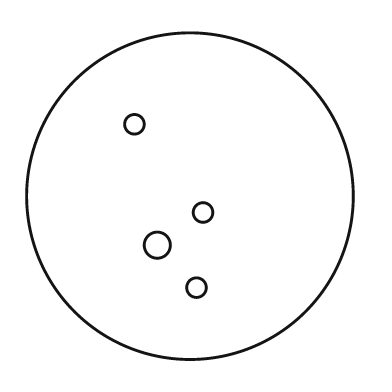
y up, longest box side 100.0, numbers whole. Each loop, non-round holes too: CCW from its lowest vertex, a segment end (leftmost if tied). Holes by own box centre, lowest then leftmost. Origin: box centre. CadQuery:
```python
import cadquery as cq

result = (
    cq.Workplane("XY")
    .moveTo(0.0, 0.0)
    .circle(50.0)
    .moveTo(2.0, -28.0)
    .circle(3.0)
    .moveTo(-10.0, -15.0)
    .circle(4.0)
    .moveTo(4.0, -5.0)
    .circle(3.0)
    .moveTo(-17.0, 22.0)
    .circle(3.0)
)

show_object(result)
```